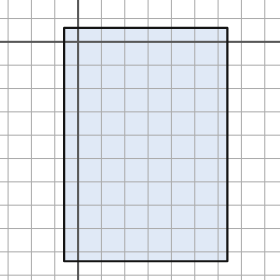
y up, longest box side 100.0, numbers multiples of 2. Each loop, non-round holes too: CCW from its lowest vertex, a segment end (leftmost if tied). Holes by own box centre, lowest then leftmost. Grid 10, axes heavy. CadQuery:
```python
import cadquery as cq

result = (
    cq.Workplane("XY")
    .moveTo(-6.0, -94.0)
    .lineTo(64.0, -94.0)
    .lineTo(64.0, 6.0)
    .lineTo(-6.0, 6.0)
    .close()
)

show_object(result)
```